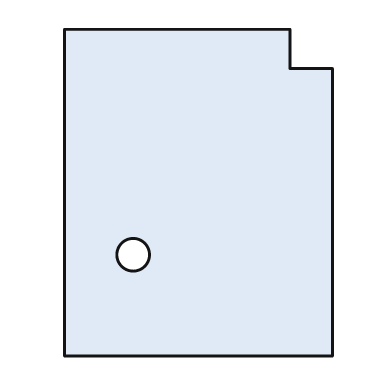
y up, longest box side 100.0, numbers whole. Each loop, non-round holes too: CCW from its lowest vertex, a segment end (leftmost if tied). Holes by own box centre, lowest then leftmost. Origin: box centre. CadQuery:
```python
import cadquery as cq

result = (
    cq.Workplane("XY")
    .moveTo(-41.0, -50.0)
    .lineTo(41.0, -50.0)
    .lineTo(41.0, 38.0)
    .lineTo(28.0, 38.0)
    .lineTo(28.0, 50.0)
    .lineTo(-41.0, 50.0)
    .close()
    .moveTo(-20.0, -19.0)
    .circle(5.0)
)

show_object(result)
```